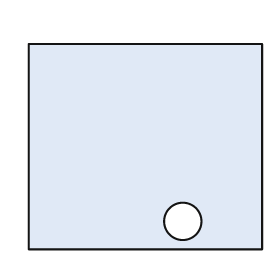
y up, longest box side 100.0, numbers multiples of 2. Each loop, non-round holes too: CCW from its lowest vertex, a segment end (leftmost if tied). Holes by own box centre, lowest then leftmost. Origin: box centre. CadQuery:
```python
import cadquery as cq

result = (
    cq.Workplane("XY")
    .moveTo(-50.0, -44.0)
    .lineTo(50.0, -44.0)
    .lineTo(50.0, 44.0)
    .lineTo(-50.0, 44.0)
    .close()
    .moveTo(16.0, -32.0)
    .circle(8.0)
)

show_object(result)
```